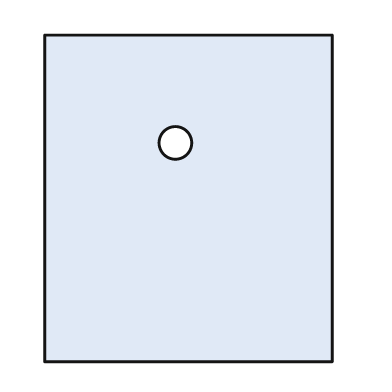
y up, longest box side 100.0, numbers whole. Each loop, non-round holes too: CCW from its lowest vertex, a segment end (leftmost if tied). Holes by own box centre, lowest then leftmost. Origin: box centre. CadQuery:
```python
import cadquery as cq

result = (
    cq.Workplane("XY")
    .moveTo(-44.0, -50.0)
    .lineTo(44.0, -50.0)
    .lineTo(44.0, 50.0)
    .lineTo(-44.0, 50.0)
    .close()
    .moveTo(-4.0, 17.0)
    .circle(5.0)
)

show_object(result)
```